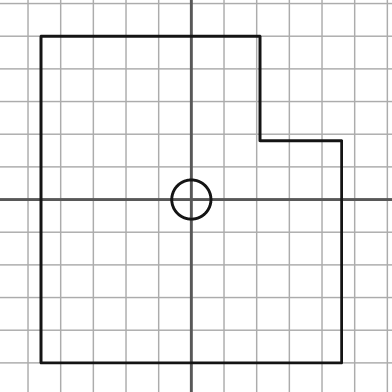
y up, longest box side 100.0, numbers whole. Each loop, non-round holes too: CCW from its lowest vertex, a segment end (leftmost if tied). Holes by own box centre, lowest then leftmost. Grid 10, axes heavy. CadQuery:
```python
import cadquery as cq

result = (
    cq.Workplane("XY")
    .moveTo(-46.0, -50.0)
    .lineTo(46.0, -50.0)
    .lineTo(46.0, 18.0)
    .lineTo(21.0, 18.0)
    .lineTo(21.0, 50.0)
    .lineTo(-46.0, 50.0)
    .close()
    .moveTo(0.0, 0.0)
    .circle(6.0)
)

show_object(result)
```